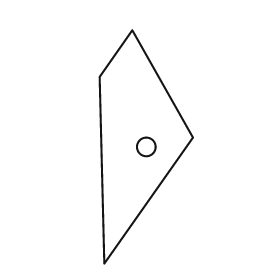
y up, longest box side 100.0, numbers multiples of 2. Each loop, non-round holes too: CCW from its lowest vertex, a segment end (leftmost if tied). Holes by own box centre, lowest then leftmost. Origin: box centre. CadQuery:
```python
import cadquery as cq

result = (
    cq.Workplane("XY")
    .moveTo(-18.0, -50.0)
    .lineTo(20.0, 4.0)
    .lineTo(-6.0, 50.0)
    .lineTo(-20.0, 30.0)
    .close()
    .moveTo(0.0, 0.0)
    .circle(4.0)
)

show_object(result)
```